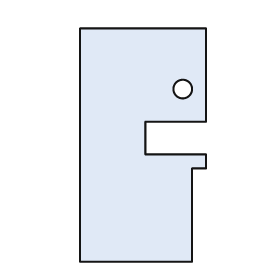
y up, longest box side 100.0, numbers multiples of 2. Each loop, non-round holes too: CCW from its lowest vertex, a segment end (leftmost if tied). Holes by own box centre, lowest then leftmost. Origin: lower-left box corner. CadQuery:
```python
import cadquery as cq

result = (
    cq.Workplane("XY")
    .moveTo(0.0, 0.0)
    .lineTo(48.0, 0.0)
    .lineTo(48.0, 40.0)
    .lineTo(54.0, 40.0)
    .lineTo(54.0, 46.0)
    .lineTo(28.0, 46.0)
    .lineTo(28.0, 60.0)
    .lineTo(54.0, 60.0)
    .lineTo(54.0, 100.0)
    .lineTo(0.0, 100.0)
    .close()
    .moveTo(44.0, 74.0)
    .circle(4.0)
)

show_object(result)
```